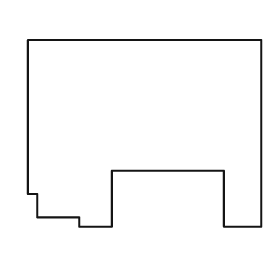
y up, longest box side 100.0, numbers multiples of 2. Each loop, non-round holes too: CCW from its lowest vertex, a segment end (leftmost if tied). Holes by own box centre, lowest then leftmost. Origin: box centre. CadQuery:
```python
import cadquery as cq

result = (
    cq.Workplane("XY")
    .moveTo(-28.0, -40.0)
    .lineTo(-14.0, -40.0)
    .lineTo(-14.0, -16.0)
    .lineTo(34.0, -16.0)
    .lineTo(34.0, -40.0)
    .lineTo(50.0, -40.0)
    .lineTo(50.0, 40.0)
    .lineTo(-50.0, 40.0)
    .lineTo(-50.0, -26.0)
    .lineTo(-46.0, -26.0)
    .lineTo(-46.0, -36.0)
    .lineTo(-28.0, -36.0)
    .close()
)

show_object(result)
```